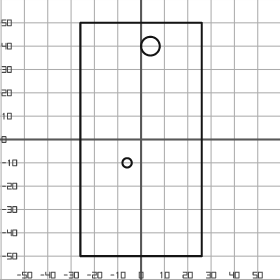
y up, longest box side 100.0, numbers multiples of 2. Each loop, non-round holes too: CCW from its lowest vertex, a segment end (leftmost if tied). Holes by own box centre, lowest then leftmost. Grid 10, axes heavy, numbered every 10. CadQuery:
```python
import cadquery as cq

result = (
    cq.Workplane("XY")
    .moveTo(-26.0, -50.0)
    .lineTo(26.0, -50.0)
    .lineTo(26.0, 50.0)
    .lineTo(-26.0, 50.0)
    .close()
    .moveTo(-6.0, -10.0)
    .circle(2.0)
    .moveTo(4.0, 40.0)
    .circle(4.0)
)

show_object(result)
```